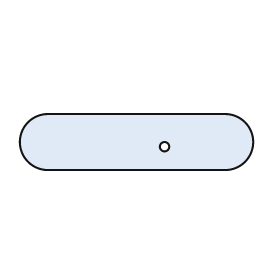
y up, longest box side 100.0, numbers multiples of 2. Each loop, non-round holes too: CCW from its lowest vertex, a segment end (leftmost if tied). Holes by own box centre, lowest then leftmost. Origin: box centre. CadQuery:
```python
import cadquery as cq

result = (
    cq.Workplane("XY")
    .moveTo(-38.0, -12.0)
    .lineTo(38.0, -12.0)
    .threePointArc((50.0, 0.0), (38.0, 12.0))
    .lineTo(-38.0, 12.0)
    .threePointArc((-50.0, 0.0), (-38.0, -12.0))
    .close()
    .moveTo(12.0, -2.0)
    .circle(2.0)
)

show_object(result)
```